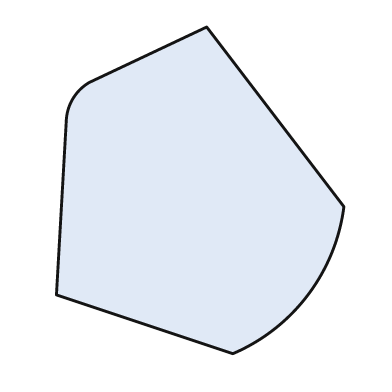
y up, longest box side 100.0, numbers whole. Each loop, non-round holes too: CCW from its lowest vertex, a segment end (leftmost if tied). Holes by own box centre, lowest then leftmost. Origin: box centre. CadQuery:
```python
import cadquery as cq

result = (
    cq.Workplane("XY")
    .moveTo(10.0, -50.0)
    .threePointArc((33.0, -32.0), (44.0, -5.0))
    .lineTo(2.0, 50.0)
    .lineTo(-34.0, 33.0)
    .threePointArc((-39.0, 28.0), (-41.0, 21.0))
    .lineTo(-44.0, -32.0)
    .close()
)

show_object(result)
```